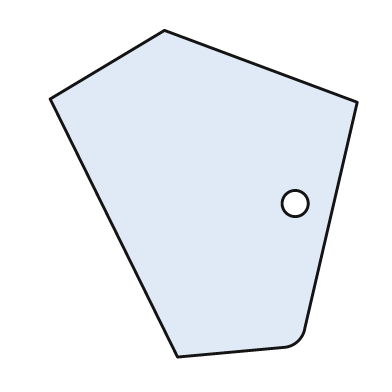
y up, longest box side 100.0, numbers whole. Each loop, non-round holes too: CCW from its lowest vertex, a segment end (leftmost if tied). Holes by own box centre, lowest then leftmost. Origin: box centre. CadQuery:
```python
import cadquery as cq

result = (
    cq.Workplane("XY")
    .moveTo(-8.0, -50.0)
    .lineTo(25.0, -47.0)
    .threePointArc((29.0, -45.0), (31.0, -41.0))
    .lineTo(47.0, 28.0)
    .lineTo(-12.0, 50.0)
    .lineTo(-47.0, 29.0)
    .close()
    .moveTo(28.0, -3.0)
    .circle(4.0)
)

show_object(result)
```